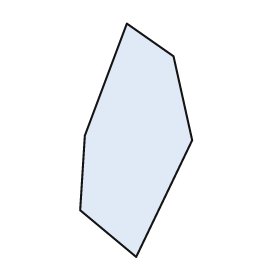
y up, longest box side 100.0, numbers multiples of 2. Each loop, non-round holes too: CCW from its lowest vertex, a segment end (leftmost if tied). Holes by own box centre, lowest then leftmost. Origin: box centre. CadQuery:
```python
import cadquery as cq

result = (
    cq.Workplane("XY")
    .moveTo(0.0, -50.0)
    .lineTo(24.0, 0.0)
    .lineTo(16.0, 36.0)
    .lineTo(-4.0, 50.0)
    .lineTo(-22.0, 2.0)
    .lineTo(-24.0, -30.0)
    .close()
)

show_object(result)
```